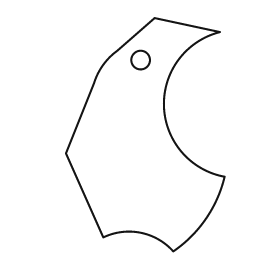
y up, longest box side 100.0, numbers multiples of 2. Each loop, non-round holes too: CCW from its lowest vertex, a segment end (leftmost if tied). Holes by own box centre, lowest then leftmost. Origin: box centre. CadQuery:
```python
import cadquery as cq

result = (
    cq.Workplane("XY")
    .moveTo(12.0, -50.0)
    .threePointArc((26.0, -36.0), (34.0, -18.0))
    .threePointArc((8.0, 12.0), (32.0, 44.0))
    .lineTo(4.0, 50.0)
    .lineTo(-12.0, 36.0)
    .threePointArc((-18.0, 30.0), (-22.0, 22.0))
    .lineTo(-34.0, -8.0)
    .lineTo(-18.0, -44.0)
    .threePointArc((-2.0, -42.0), (12.0, -50.0))
    .close()
    .moveTo(-2.0, 32.0)
    .circle(4.0)
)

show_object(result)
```